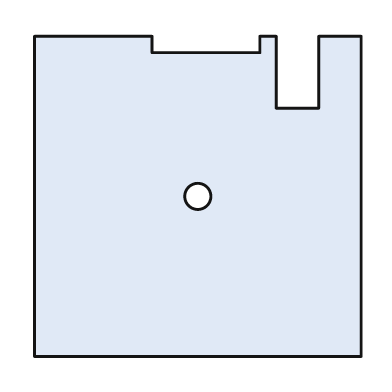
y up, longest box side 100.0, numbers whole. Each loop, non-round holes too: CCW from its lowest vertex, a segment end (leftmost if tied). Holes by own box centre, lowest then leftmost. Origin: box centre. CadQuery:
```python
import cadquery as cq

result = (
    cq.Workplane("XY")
    .moveTo(-50.0, -49.0)
    .lineTo(50.0, -49.0)
    .lineTo(50.0, 49.0)
    .lineTo(37.0, 49.0)
    .lineTo(37.0, 27.0)
    .lineTo(24.0, 27.0)
    .lineTo(24.0, 49.0)
    .lineTo(19.0, 49.0)
    .lineTo(19.0, 44.0)
    .lineTo(-14.0, 44.0)
    .lineTo(-14.0, 49.0)
    .lineTo(-50.0, 49.0)
    .close()
    .moveTo(0.0, 0.0)
    .circle(4.0)
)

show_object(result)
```